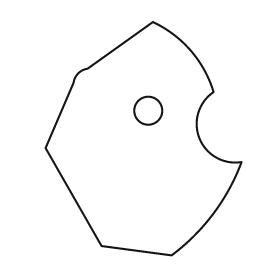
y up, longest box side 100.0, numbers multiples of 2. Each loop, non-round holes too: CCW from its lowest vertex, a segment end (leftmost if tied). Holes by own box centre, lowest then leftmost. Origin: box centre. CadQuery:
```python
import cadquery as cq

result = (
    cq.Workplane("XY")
    .moveTo(12.0, -50.0)
    .threePointArc((30.0, -32.0), (42.0, -10.0))
    .threePointArc((24.0, 0.0), (30.0, 20.0))
    .threePointArc((20.0, 38.0), (4.0, 50.0))
    .lineTo(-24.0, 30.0)
    .threePointArc((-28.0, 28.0), (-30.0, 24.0))
    .lineTo(-42.0, -4.0)
    .lineTo(-18.0, -46.0)
    .close()
    .moveTo(2.0, 12.0)
    .circle(6.0)
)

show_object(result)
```